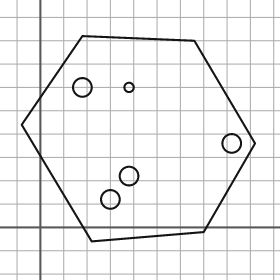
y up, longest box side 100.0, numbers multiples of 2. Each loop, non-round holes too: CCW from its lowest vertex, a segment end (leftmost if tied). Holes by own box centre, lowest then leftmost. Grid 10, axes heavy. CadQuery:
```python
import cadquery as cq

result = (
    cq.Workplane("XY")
    .moveTo(22.0, -6.0)
    .lineTo(70.0, -2.0)
    .lineTo(92.0, 36.0)
    .lineTo(66.0, 80.0)
    .lineTo(18.0, 82.0)
    .lineTo(-8.0, 44.0)
    .close()
    .moveTo(30.0, 12.0)
    .circle(4.0)
    .moveTo(38.0, 22.0)
    .circle(4.0)
    .moveTo(82.0, 36.0)
    .circle(4.0)
    .moveTo(18.0, 60.0)
    .circle(4.0)
    .moveTo(38.0, 60.0)
    .circle(2.0)
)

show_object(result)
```